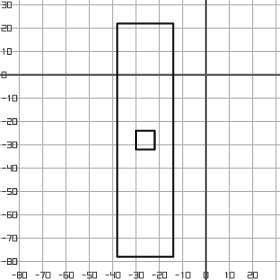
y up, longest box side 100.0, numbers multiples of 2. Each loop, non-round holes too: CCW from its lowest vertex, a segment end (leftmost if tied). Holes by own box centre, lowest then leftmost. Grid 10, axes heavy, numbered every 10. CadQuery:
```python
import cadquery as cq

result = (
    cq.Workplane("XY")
    .moveTo(-38.0, -78.0)
    .lineTo(-14.0, -78.0)
    .lineTo(-14.0, 22.0)
    .lineTo(-38.0, 22.0)
    .close()
    .moveTo(-30.0, -32.0)
    .lineTo(-22.0, -32.0)
    .lineTo(-22.0, -24.0)
    .lineTo(-30.0, -24.0)
    .close()
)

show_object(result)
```